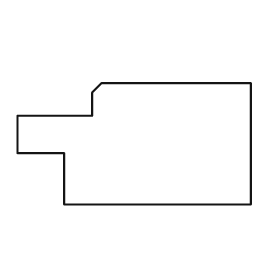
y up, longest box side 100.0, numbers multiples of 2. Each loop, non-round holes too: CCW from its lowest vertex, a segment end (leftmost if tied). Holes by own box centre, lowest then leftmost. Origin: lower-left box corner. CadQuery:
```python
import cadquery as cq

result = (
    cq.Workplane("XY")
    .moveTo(20.0, 0.0)
    .lineTo(100.0, 0.0)
    .lineTo(100.0, 52.0)
    .lineTo(36.0, 52.0)
    .lineTo(32.0, 48.0)
    .lineTo(32.0, 38.0)
    .lineTo(0.0, 38.0)
    .lineTo(0.0, 22.0)
    .lineTo(20.0, 22.0)
    .close()
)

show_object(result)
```